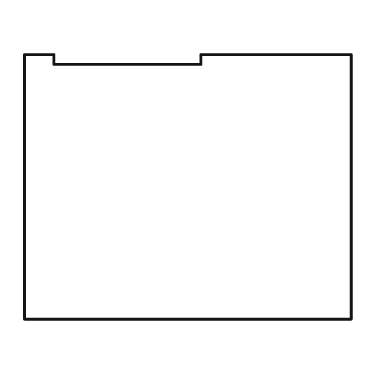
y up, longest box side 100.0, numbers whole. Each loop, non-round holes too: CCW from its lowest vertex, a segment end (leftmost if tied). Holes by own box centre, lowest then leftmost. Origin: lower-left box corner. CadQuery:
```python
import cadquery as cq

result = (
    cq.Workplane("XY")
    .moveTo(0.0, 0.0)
    .lineTo(100.0, 0.0)
    .lineTo(100.0, 81.0)
    .lineTo(54.0, 81.0)
    .lineTo(54.0, 78.0)
    .lineTo(9.0, 78.0)
    .lineTo(9.0, 81.0)
    .lineTo(0.0, 81.0)
    .close()
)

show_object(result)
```